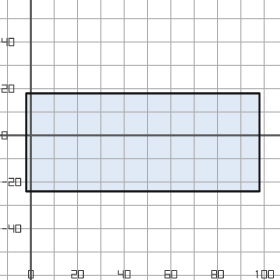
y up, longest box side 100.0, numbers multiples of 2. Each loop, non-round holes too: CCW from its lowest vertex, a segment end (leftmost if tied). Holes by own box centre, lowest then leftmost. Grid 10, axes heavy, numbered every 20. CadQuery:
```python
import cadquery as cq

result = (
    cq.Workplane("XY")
    .moveTo(-2.0, -24.0)
    .lineTo(98.0, -24.0)
    .lineTo(98.0, 18.0)
    .lineTo(-2.0, 18.0)
    .close()
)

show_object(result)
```